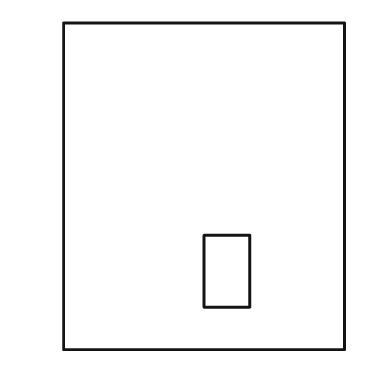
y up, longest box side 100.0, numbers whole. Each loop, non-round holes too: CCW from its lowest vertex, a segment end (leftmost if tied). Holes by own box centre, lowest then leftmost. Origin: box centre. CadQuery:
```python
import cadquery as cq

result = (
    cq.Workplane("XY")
    .moveTo(-43.0, -50.0)
    .lineTo(43.0, -50.0)
    .lineTo(43.0, 50.0)
    .lineTo(-43.0, 50.0)
    .close()
    .moveTo(0.0, -37.0)
    .lineTo(14.0, -37.0)
    .lineTo(14.0, -15.0)
    .lineTo(0.0, -15.0)
    .close()
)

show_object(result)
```